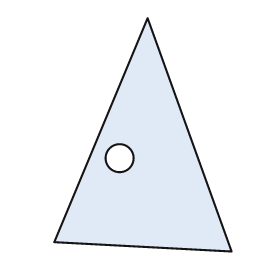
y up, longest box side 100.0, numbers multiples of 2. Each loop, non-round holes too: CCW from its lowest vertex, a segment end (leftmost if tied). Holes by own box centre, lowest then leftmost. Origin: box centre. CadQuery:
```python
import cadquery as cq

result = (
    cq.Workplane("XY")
    .moveTo(38.0, -50.0)
    .lineTo(2.0, 50.0)
    .lineTo(-38.0, -46.0)
    .close()
    .moveTo(-10.0, -10.0)
    .circle(6.0)
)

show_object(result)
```